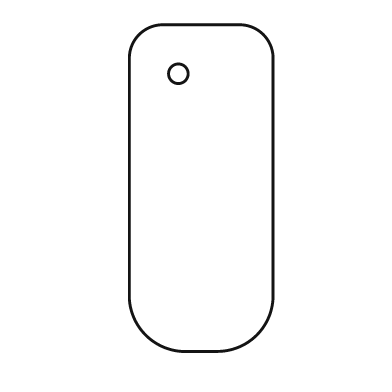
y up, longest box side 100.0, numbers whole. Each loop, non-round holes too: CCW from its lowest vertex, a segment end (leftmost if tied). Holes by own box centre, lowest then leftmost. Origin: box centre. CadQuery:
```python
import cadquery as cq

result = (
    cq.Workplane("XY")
    .moveTo(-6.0, -50.0)
    .lineTo(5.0, -50.0)
    .threePointArc((17.0, -45.0), (22.0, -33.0))
    .lineTo(22.0, 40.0)
    .threePointArc((19.0, 47.0), (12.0, 50.0))
    .lineTo(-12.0, 50.0)
    .threePointArc((-19.0, 47.0), (-22.0, 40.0))
    .lineTo(-22.0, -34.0)
    .threePointArc((-17.0, -45.0), (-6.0, -50.0))
    .close()
    .moveTo(-7.0, 35.0)
    .circle(3.0)
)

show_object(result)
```